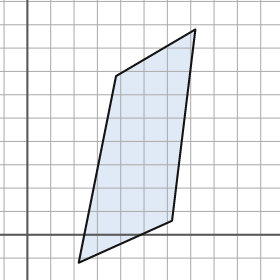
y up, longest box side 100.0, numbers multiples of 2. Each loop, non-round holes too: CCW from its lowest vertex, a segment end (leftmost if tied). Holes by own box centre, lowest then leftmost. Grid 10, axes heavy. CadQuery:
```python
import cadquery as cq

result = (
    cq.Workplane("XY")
    .moveTo(22.0, -12.0)
    .lineTo(62.0, 6.0)
    .lineTo(72.0, 88.0)
    .lineTo(38.0, 68.0)
    .close()
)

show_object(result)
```